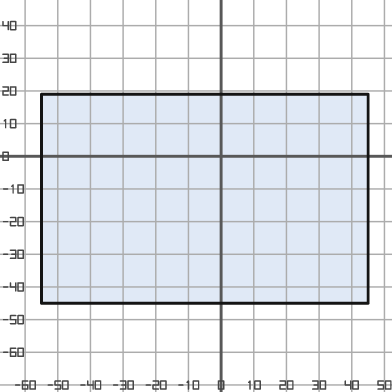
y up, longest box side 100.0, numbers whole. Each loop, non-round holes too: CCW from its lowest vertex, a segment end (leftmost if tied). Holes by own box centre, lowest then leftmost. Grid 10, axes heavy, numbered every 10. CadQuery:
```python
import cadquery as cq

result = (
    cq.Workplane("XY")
    .moveTo(-55.0, -45.0)
    .lineTo(45.0, -45.0)
    .lineTo(45.0, 19.0)
    .lineTo(-55.0, 19.0)
    .close()
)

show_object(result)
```